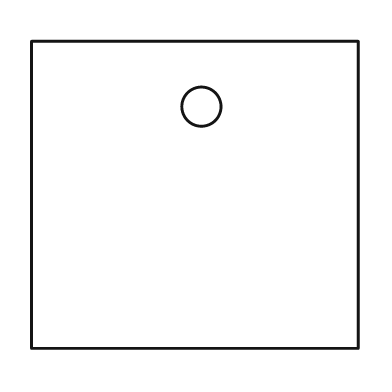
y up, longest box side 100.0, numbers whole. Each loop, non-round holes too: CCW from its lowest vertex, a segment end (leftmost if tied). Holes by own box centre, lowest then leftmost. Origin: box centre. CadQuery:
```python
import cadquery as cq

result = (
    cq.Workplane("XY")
    .moveTo(-50.0, -47.0)
    .lineTo(50.0, -47.0)
    .lineTo(50.0, 47.0)
    .lineTo(-50.0, 47.0)
    .close()
    .moveTo(2.0, 27.0)
    .circle(6.0)
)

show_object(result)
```